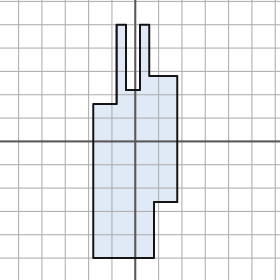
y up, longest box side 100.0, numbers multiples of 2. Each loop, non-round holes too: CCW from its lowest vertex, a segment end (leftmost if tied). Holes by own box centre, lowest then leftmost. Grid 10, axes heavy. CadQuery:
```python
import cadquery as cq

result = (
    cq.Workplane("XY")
    .moveTo(-18.0, -50.0)
    .lineTo(8.0, -50.0)
    .lineTo(8.0, -26.0)
    .lineTo(18.0, -26.0)
    .lineTo(18.0, 28.0)
    .lineTo(6.0, 28.0)
    .lineTo(6.0, 50.0)
    .lineTo(2.0, 50.0)
    .lineTo(2.0, 22.0)
    .lineTo(-4.0, 22.0)
    .lineTo(-4.0, 50.0)
    .lineTo(-8.0, 50.0)
    .lineTo(-8.0, 16.0)
    .lineTo(-18.0, 16.0)
    .close()
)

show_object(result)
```